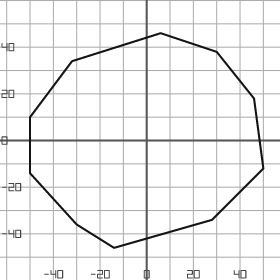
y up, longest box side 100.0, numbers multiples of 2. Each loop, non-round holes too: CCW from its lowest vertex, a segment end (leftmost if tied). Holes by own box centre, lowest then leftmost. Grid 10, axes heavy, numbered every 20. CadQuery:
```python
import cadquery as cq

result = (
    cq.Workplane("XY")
    .moveTo(-14.0, -46.0)
    .lineTo(28.0, -34.0)
    .lineTo(50.0, -12.0)
    .lineTo(46.0, 18.0)
    .lineTo(30.0, 38.0)
    .lineTo(6.0, 46.0)
    .lineTo(-32.0, 34.0)
    .lineTo(-50.0, 10.0)
    .lineTo(-50.0, -14.0)
    .lineTo(-30.0, -36.0)
    .close()
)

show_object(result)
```